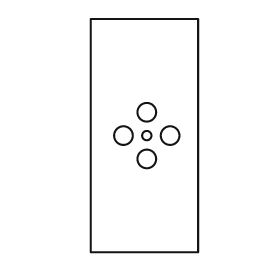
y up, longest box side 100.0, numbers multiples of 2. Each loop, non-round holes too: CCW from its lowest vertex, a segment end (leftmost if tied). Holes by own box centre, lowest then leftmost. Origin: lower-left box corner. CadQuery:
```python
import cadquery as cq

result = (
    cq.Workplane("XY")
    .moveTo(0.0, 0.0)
    .lineTo(46.0, 0.0)
    .lineTo(46.0, 100.0)
    .lineTo(0.0, 100.0)
    .close()
    .moveTo(24.0, 40.0)
    .circle(4.0)
    .moveTo(14.0, 50.0)
    .circle(4.0)
    .moveTo(24.0, 50.0)
    .circle(2.0)
    .moveTo(34.0, 50.0)
    .circle(4.0)
    .moveTo(24.0, 60.0)
    .circle(4.0)
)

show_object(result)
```